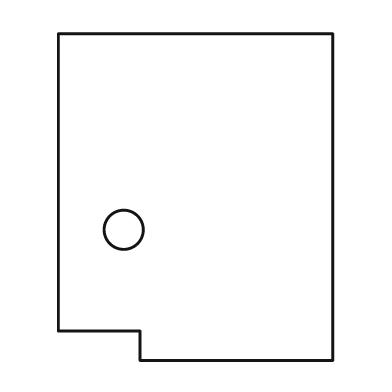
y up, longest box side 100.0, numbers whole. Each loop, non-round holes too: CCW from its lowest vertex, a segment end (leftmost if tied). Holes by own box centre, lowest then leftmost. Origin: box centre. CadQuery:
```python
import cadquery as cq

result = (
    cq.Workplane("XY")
    .moveTo(-17.0, -50.0)
    .lineTo(42.0, -50.0)
    .lineTo(42.0, 50.0)
    .lineTo(-42.0, 50.0)
    .lineTo(-42.0, -41.0)
    .lineTo(-17.0, -41.0)
    .close()
    .moveTo(-22.0, -10.0)
    .circle(6.0)
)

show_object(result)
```